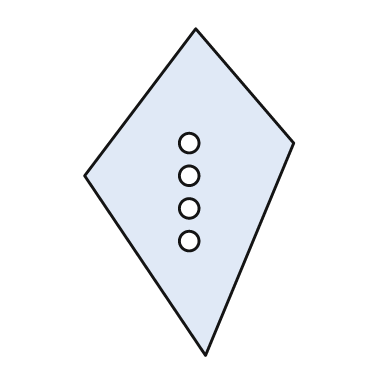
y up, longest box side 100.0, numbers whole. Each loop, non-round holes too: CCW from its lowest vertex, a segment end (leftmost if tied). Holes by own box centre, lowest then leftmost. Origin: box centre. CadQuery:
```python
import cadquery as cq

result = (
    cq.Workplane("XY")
    .moveTo(5.0, -50.0)
    .lineTo(32.0, 15.0)
    .lineTo(2.0, 50.0)
    .lineTo(-32.0, 5.0)
    .close()
    .moveTo(0.0, -15.0)
    .circle(3.0)
    .moveTo(0.0, -5.0)
    .circle(3.0)
    .moveTo(0.0, 5.0)
    .circle(3.0)
    .moveTo(0.0, 15.0)
    .circle(3.0)
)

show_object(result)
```